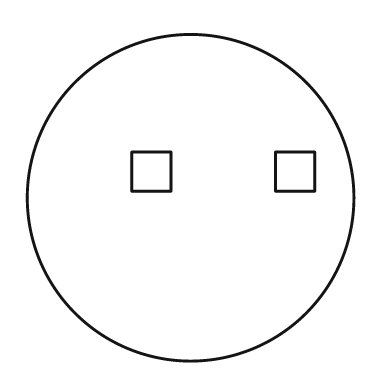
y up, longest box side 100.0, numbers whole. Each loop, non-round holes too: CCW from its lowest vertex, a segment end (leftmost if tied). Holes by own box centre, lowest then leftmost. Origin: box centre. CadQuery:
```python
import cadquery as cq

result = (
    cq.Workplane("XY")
    .moveTo(0.0, 0.0)
    .circle(50.0)
    .moveTo(-18.0, 2.0)
    .lineTo(-6.0, 2.0)
    .lineTo(-6.0, 14.0)
    .lineTo(-18.0, 14.0)
    .close()
    .moveTo(26.0, 2.0)
    .lineTo(38.0, 2.0)
    .lineTo(38.0, 14.0)
    .lineTo(26.0, 14.0)
    .close()
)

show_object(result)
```